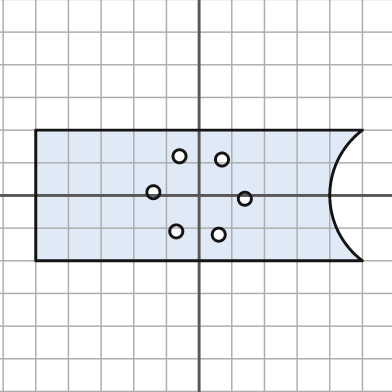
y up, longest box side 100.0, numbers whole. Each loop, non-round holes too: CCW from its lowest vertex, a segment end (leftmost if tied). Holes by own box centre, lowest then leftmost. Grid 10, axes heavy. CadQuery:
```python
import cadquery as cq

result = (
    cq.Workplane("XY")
    .moveTo(-50.0, -20.0)
    .lineTo(50.0, -20.0)
    .threePointArc((40.0, 0.0), (50.0, 20.0))
    .lineTo(-50.0, 20.0)
    .close()
    .moveTo(6.0, -12.0)
    .circle(2.0)
    .moveTo(-7.0, -11.0)
    .circle(2.0)
    .moveTo(14.0, -1.0)
    .circle(2.0)
    .moveTo(-14.0, 1.0)
    .circle(2.0)
    .moveTo(7.0, 11.0)
    .circle(2.0)
    .moveTo(-6.0, 12.0)
    .circle(2.0)
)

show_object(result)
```